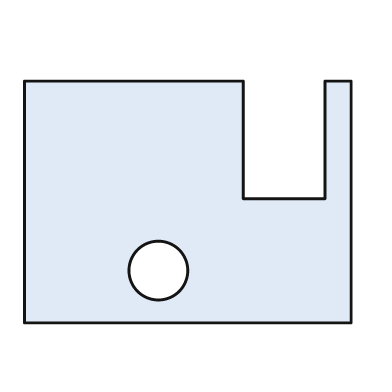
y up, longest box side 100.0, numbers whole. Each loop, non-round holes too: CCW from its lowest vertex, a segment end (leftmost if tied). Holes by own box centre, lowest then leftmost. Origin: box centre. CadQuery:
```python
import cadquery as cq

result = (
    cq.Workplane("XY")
    .moveTo(-50.0, -37.0)
    .lineTo(50.0, -37.0)
    .lineTo(50.0, 37.0)
    .lineTo(42.0, 37.0)
    .lineTo(42.0, 1.0)
    .lineTo(17.0, 1.0)
    .lineTo(17.0, 37.0)
    .lineTo(-50.0, 37.0)
    .close()
    .moveTo(-9.0, -21.0)
    .circle(9.0)
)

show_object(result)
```